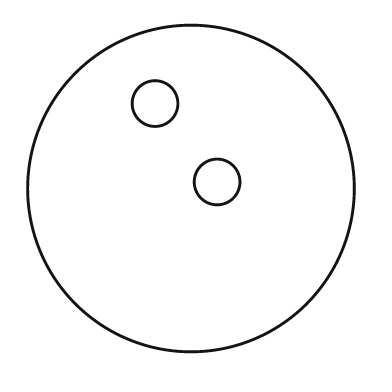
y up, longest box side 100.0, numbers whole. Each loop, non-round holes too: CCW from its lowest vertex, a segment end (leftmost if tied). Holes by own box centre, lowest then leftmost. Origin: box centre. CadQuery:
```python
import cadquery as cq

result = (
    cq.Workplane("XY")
    .moveTo(0.0, 0.0)
    .circle(50.0)
    .moveTo(8.0, 2.0)
    .circle(7.0)
    .moveTo(-11.0, 26.0)
    .circle(7.0)
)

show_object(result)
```